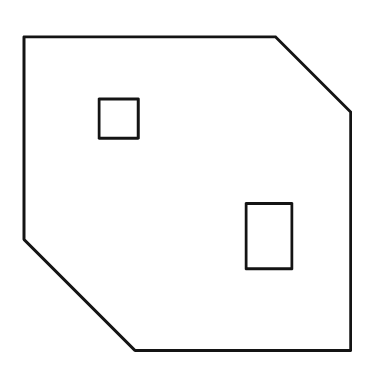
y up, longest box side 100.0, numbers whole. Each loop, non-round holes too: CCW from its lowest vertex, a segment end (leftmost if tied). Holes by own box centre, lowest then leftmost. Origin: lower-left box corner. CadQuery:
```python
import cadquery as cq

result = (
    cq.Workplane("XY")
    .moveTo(34.0, 0.0)
    .lineTo(100.0, 0.0)
    .lineTo(100.0, 73.0)
    .lineTo(77.0, 96.0)
    .lineTo(0.0, 96.0)
    .lineTo(0.0, 34.0)
    .close()
    .moveTo(68.0, 25.0)
    .lineTo(82.0, 25.0)
    .lineTo(82.0, 45.0)
    .lineTo(68.0, 45.0)
    .close()
    .moveTo(23.0, 65.0)
    .lineTo(35.0, 65.0)
    .lineTo(35.0, 77.0)
    .lineTo(23.0, 77.0)
    .close()
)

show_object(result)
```